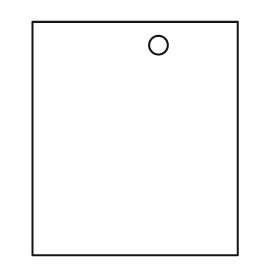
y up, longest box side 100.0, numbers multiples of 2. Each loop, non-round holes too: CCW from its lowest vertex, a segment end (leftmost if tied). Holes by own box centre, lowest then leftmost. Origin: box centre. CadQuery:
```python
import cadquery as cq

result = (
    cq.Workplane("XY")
    .moveTo(-44.0, -50.0)
    .lineTo(44.0, -50.0)
    .lineTo(44.0, 50.0)
    .lineTo(-44.0, 50.0)
    .close()
    .moveTo(10.0, 40.0)
    .circle(4.0)
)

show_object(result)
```